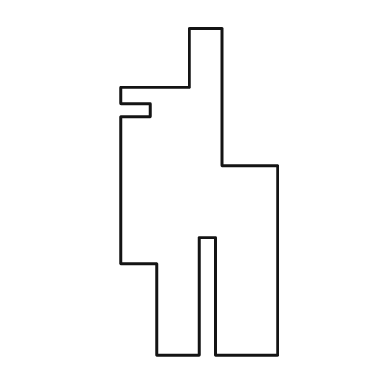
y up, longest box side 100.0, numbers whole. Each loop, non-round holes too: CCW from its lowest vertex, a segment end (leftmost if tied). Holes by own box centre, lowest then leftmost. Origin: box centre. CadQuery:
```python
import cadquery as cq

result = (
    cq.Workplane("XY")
    .moveTo(-13.0, -50.0)
    .lineTo(0.0, -50.0)
    .lineTo(0.0, -14.0)
    .lineTo(5.0, -14.0)
    .lineTo(5.0, -50.0)
    .lineTo(24.0, -50.0)
    .lineTo(24.0, 8.0)
    .lineTo(7.0, 8.0)
    .lineTo(7.0, 50.0)
    .lineTo(-3.0, 50.0)
    .lineTo(-3.0, 32.0)
    .lineTo(-24.0, 32.0)
    .lineTo(-24.0, 27.0)
    .lineTo(-15.0, 27.0)
    .lineTo(-15.0, 23.0)
    .lineTo(-24.0, 23.0)
    .lineTo(-24.0, -22.0)
    .lineTo(-13.0, -22.0)
    .close()
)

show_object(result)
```